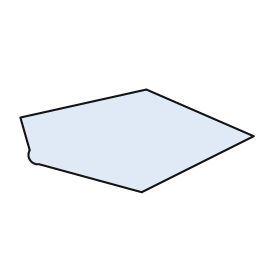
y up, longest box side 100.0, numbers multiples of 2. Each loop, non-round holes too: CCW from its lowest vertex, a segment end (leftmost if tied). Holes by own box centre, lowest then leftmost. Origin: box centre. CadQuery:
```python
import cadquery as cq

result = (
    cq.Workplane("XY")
    .moveTo(2.0, -22.0)
    .lineTo(50.0, 2.0)
    .lineTo(4.0, 22.0)
    .lineTo(-50.0, 10.0)
    .lineTo(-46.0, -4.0)
    .threePointArc((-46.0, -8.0), (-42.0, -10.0))
    .close()
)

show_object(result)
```